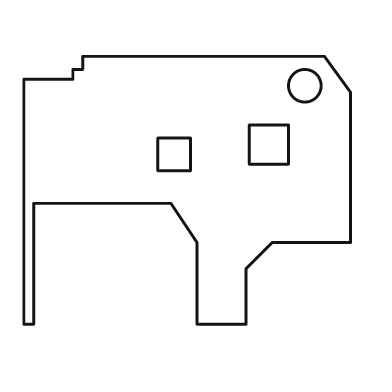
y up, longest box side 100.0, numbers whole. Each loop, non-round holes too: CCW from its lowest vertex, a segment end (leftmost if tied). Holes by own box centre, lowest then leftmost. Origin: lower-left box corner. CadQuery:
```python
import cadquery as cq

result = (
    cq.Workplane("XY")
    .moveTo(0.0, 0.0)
    .lineTo(3.0, 0.0)
    .lineTo(3.0, 37.0)
    .lineTo(45.0, 37.0)
    .lineTo(53.0, 25.0)
    .lineTo(53.0, 0.0)
    .lineTo(68.0, 0.0)
    .lineTo(68.0, 17.0)
    .lineTo(76.0, 25.0)
    .lineTo(100.0, 25.0)
    .lineTo(100.0, 71.0)
    .lineTo(92.0, 82.0)
    .lineTo(18.0, 82.0)
    .lineTo(18.0, 78.0)
    .lineTo(15.0, 78.0)
    .lineTo(15.0, 75.0)
    .lineTo(0.0, 75.0)
    .close()
    .moveTo(41.0, 47.0)
    .lineTo(51.0, 47.0)
    .lineTo(51.0, 57.0)
    .lineTo(41.0, 57.0)
    .close()
    .moveTo(69.0, 49.0)
    .lineTo(81.0, 49.0)
    .lineTo(81.0, 61.0)
    .lineTo(69.0, 61.0)
    .close()
    .moveTo(86.0, 73.0)
    .circle(5.0)
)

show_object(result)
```